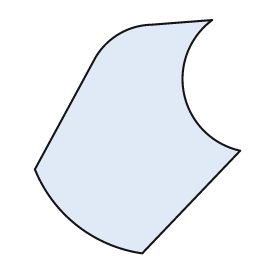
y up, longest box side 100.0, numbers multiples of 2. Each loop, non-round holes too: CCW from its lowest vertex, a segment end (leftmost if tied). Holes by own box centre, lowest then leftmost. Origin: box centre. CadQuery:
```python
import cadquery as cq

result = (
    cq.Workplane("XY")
    .moveTo(2.0, -50.0)
    .lineTo(44.0, -6.0)
    .threePointArc((20.0, 18.0), (32.0, 50.0))
    .lineTo(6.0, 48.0)
    .threePointArc((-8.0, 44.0), (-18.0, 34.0))
    .lineTo(-44.0, -14.0)
    .threePointArc((-26.0, -38.0), (2.0, -50.0))
    .close()
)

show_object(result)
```